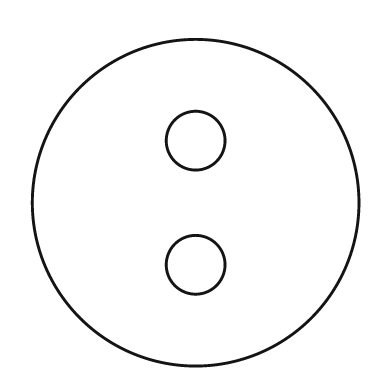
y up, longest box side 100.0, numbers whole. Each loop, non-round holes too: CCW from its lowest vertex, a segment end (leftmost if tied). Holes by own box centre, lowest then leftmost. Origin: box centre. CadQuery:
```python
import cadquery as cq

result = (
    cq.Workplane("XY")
    .moveTo(0.0, 0.0)
    .circle(50.0)
    .moveTo(0.0, -19.0)
    .circle(9.0)
    .moveTo(0.0, 19.0)
    .circle(9.0)
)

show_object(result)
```